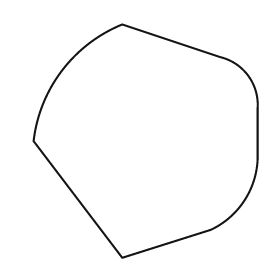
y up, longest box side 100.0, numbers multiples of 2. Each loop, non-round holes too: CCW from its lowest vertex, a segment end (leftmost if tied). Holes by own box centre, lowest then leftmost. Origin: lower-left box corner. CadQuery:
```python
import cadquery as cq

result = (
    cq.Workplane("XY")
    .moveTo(38.0, 0.0)
    .lineTo(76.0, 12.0)
    .threePointArc((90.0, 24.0), (96.0, 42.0))
    .lineTo(96.0, 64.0)
    .threePointArc((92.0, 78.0), (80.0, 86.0))
    .lineTo(38.0, 100.0)
    .threePointArc((12.0, 80.0), (0.0, 50.0))
    .close()
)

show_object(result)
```